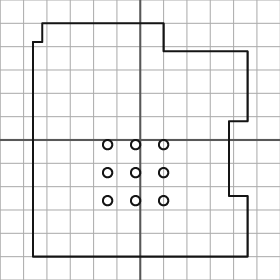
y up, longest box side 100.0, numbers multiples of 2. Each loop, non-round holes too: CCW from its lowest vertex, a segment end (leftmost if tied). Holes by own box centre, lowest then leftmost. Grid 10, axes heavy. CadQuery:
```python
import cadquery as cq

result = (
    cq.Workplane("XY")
    .moveTo(-46.0, -50.0)
    .lineTo(46.0, -50.0)
    .lineTo(46.0, -24.0)
    .lineTo(38.0, -24.0)
    .lineTo(38.0, 8.0)
    .lineTo(46.0, 8.0)
    .lineTo(46.0, 38.0)
    .lineTo(10.0, 38.0)
    .lineTo(10.0, 50.0)
    .lineTo(-42.0, 50.0)
    .lineTo(-42.0, 42.0)
    .lineTo(-46.0, 42.0)
    .close()
    .moveTo(-14.0, -26.0)
    .circle(2.0)
    .moveTo(-2.0, -26.0)
    .circle(2.0)
    .moveTo(10.0, -26.0)
    .circle(2.0)
    .moveTo(-14.0, -14.0)
    .circle(2.0)
    .moveTo(-2.0, -14.0)
    .circle(2.0)
    .moveTo(10.0, -14.0)
    .circle(2.0)
    .moveTo(-14.0, -2.0)
    .circle(2.0)
    .moveTo(-2.0, -2.0)
    .circle(2.0)
    .moveTo(10.0, -2.0)
    .circle(2.0)
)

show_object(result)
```